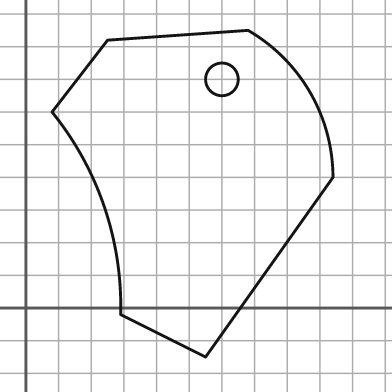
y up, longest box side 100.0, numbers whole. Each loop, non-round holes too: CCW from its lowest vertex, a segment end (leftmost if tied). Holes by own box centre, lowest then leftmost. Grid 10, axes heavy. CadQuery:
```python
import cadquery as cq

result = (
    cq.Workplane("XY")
    .moveTo(55.0, -15.0)
    .lineTo(94.0, 40.0)
    .threePointArc((87.0, 66.0), (68.0, 85.0))
    .lineTo(25.0, 82.0)
    .lineTo(8.0, 60.0)
    .threePointArc((24.0, 31.0), (29.0, -2.0))
    .close()
    .moveTo(60.0, 70.0)
    .circle(5.0)
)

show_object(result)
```